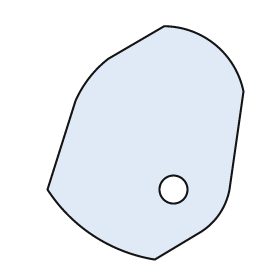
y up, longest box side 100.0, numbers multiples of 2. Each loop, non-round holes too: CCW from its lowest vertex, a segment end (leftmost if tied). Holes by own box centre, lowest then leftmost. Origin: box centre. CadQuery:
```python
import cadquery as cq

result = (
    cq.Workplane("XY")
    .moveTo(4.0, -50.0)
    .lineTo(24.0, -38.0)
    .threePointArc((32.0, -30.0), (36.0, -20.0))
    .lineTo(42.0, 22.0)
    .threePointArc((30.0, 42.0), (8.0, 50.0))
    .lineTo(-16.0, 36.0)
    .threePointArc((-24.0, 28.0), (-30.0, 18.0))
    .lineTo(-42.0, -20.0)
    .threePointArc((-22.0, -40.0), (4.0, -50.0))
    .close()
    .moveTo(12.0, -20.0)
    .circle(6.0)
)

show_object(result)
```